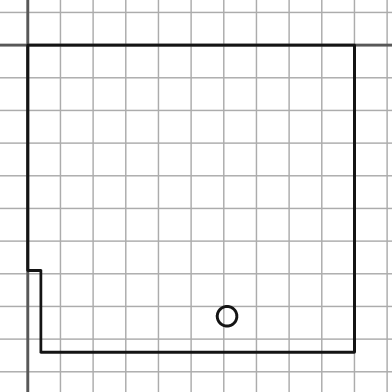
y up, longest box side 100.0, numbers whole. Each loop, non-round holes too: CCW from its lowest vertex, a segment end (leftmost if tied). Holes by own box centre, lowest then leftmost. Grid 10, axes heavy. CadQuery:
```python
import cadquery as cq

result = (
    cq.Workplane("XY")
    .moveTo(4.0, -94.0)
    .lineTo(100.0, -94.0)
    .lineTo(100.0, 0.0)
    .lineTo(0.0, 0.0)
    .lineTo(0.0, -69.0)
    .lineTo(4.0, -69.0)
    .close()
    .moveTo(61.0, -83.0)
    .circle(3.0)
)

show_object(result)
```